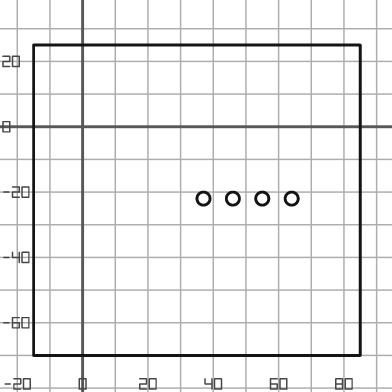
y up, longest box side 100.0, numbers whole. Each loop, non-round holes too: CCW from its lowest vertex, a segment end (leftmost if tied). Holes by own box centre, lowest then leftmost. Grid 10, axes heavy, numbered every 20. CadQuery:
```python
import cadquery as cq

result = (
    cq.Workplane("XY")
    .moveTo(-15.0, -70.0)
    .lineTo(85.0, -70.0)
    .lineTo(85.0, 25.0)
    .lineTo(-15.0, 25.0)
    .close()
    .moveTo(37.0, -22.0)
    .circle(2.0)
    .moveTo(46.0, -22.0)
    .circle(2.0)
    .moveTo(55.0, -22.0)
    .circle(2.0)
    .moveTo(64.0, -22.0)
    .circle(2.0)
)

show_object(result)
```